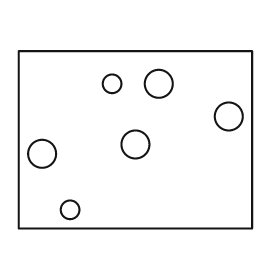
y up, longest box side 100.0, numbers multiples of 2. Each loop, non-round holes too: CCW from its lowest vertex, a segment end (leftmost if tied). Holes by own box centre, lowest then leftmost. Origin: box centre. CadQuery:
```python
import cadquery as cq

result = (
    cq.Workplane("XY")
    .moveTo(-50.0, -38.0)
    .lineTo(50.0, -38.0)
    .lineTo(50.0, 38.0)
    .lineTo(-50.0, 38.0)
    .close()
    .moveTo(-28.0, -30.0)
    .circle(4.0)
    .moveTo(-40.0, -6.0)
    .circle(6.0)
    .moveTo(0.0, -2.0)
    .circle(6.0)
    .moveTo(40.0, 10.0)
    .circle(6.0)
    .moveTo(-10.0, 24.0)
    .circle(4.0)
    .moveTo(10.0, 24.0)
    .circle(6.0)
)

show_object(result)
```